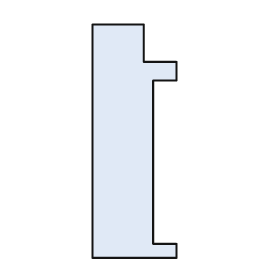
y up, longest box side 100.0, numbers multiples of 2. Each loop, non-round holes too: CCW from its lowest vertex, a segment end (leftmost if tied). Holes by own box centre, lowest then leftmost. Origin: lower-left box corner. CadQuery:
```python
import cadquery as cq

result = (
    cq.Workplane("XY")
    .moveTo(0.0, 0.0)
    .lineTo(36.0, 0.0)
    .lineTo(36.0, 6.0)
    .lineTo(26.0, 6.0)
    .lineTo(26.0, 76.0)
    .lineTo(36.0, 76.0)
    .lineTo(36.0, 84.0)
    .lineTo(22.0, 84.0)
    .lineTo(22.0, 100.0)
    .lineTo(0.0, 100.0)
    .close()
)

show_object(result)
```